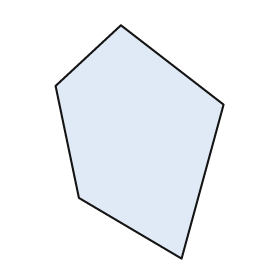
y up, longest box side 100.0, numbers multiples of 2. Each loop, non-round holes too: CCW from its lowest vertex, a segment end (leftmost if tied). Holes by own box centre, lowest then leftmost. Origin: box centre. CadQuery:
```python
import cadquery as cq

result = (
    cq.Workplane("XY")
    .moveTo(18.0, -50.0)
    .lineTo(36.0, 16.0)
    .lineTo(-8.0, 50.0)
    .lineTo(-36.0, 24.0)
    .lineTo(-26.0, -24.0)
    .close()
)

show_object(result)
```